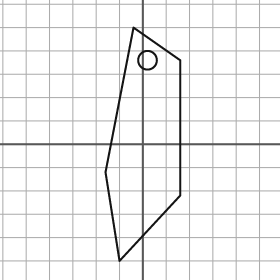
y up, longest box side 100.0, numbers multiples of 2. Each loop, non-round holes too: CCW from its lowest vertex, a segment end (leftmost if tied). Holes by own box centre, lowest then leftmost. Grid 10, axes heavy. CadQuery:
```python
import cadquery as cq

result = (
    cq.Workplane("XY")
    .moveTo(-10.0, -50.0)
    .lineTo(16.0, -22.0)
    .lineTo(16.0, 36.0)
    .lineTo(-4.0, 50.0)
    .lineTo(-16.0, -12.0)
    .close()
    .moveTo(2.0, 36.0)
    .circle(4.0)
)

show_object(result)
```